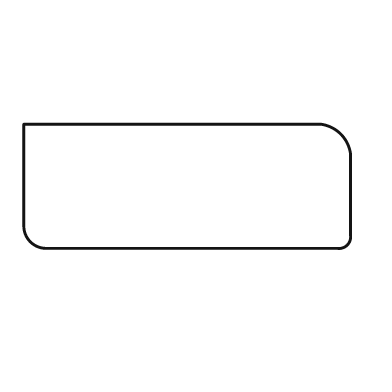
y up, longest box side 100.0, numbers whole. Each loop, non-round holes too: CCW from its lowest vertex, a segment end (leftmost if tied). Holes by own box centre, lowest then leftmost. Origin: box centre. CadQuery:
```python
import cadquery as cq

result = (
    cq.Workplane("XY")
    .moveTo(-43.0, -19.0)
    .lineTo(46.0, -19.0)
    .threePointArc((49.0, -18.0), (50.0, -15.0))
    .lineTo(50.0, 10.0)
    .threePointArc((47.0, 16.0), (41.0, 19.0))
    .lineTo(-50.0, 19.0)
    .lineTo(-50.0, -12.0)
    .threePointArc((-48.0, -17.0), (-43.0, -19.0))
    .close()
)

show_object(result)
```